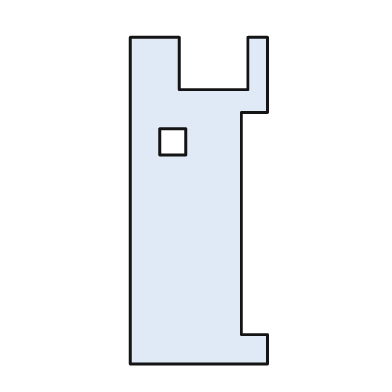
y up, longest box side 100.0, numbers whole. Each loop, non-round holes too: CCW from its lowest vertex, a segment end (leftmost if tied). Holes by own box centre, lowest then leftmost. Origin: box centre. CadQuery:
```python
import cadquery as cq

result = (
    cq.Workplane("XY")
    .moveTo(-21.0, -50.0)
    .lineTo(21.0, -50.0)
    .lineTo(21.0, -41.0)
    .lineTo(13.0, -41.0)
    .lineTo(13.0, 27.0)
    .lineTo(21.0, 27.0)
    .lineTo(21.0, 50.0)
    .lineTo(15.0, 50.0)
    .lineTo(15.0, 34.0)
    .lineTo(-6.0, 34.0)
    .lineTo(-6.0, 50.0)
    .lineTo(-21.0, 50.0)
    .close()
    .moveTo(-12.0, 14.0)
    .lineTo(-4.0, 14.0)
    .lineTo(-4.0, 22.0)
    .lineTo(-12.0, 22.0)
    .close()
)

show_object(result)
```